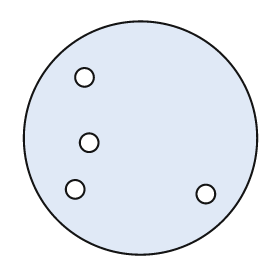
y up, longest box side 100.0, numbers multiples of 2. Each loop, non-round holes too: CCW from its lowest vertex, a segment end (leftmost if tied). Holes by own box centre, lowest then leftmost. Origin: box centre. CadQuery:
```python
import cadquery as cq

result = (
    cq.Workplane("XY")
    .moveTo(0.0, 0.0)
    .circle(50.0)
    .moveTo(28.0, -24.0)
    .circle(4.0)
    .moveTo(-28.0, -22.0)
    .circle(4.0)
    .moveTo(-22.0, -2.0)
    .circle(4.0)
    .moveTo(-24.0, 26.0)
    .circle(4.0)
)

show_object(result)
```